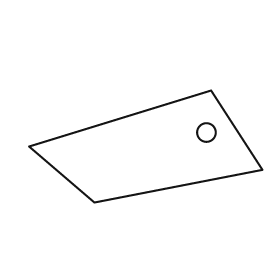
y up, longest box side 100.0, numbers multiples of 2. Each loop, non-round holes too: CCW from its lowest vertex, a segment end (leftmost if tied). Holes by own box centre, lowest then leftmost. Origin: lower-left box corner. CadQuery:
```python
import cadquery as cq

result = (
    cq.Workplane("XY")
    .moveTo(28.0, 0.0)
    .lineTo(100.0, 14.0)
    .lineTo(78.0, 48.0)
    .lineTo(0.0, 24.0)
    .close()
    .moveTo(76.0, 30.0)
    .circle(4.0)
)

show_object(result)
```